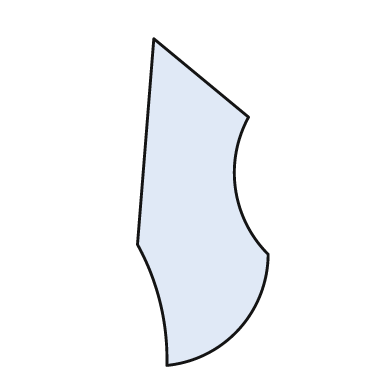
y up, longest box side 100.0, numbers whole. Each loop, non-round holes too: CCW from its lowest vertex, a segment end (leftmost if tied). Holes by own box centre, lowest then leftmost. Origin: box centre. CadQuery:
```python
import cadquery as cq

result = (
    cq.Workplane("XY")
    .moveTo(-11.0, -50.0)
    .threePointArc((11.0, -39.0), (20.0, -16.0))
    .threePointArc((10.0, 4.0), (14.0, 26.0))
    .lineTo(-15.0, 50.0)
    .lineTo(-20.0, -13.0)
    .threePointArc((-13.0, -31.0), (-11.0, -50.0))
    .close()
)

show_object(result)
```